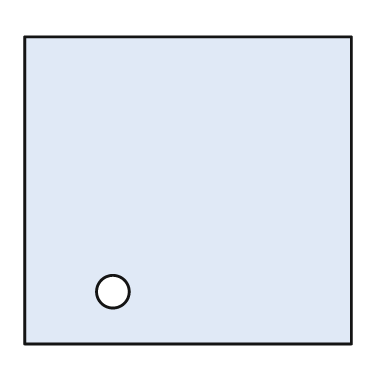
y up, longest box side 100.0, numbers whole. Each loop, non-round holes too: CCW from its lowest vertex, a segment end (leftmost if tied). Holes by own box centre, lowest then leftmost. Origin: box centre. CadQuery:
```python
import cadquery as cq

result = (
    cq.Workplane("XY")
    .moveTo(-50.0, -47.0)
    .lineTo(50.0, -47.0)
    .lineTo(50.0, 47.0)
    .lineTo(-50.0, 47.0)
    .close()
    .moveTo(-23.0, -31.0)
    .circle(5.0)
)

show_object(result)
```